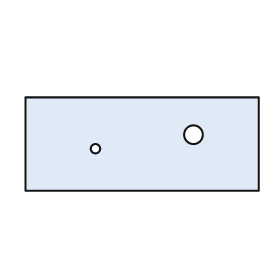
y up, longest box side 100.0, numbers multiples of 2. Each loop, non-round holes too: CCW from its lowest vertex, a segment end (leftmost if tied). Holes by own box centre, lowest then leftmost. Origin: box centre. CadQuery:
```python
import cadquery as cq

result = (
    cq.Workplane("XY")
    .moveTo(-50.0, -20.0)
    .lineTo(50.0, -20.0)
    .lineTo(50.0, 20.0)
    .lineTo(-50.0, 20.0)
    .close()
    .moveTo(-20.0, -2.0)
    .circle(2.0)
    .moveTo(22.0, 4.0)
    .circle(4.0)
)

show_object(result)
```